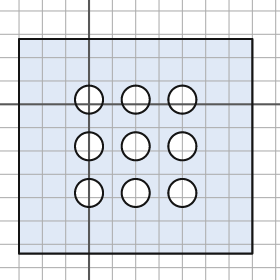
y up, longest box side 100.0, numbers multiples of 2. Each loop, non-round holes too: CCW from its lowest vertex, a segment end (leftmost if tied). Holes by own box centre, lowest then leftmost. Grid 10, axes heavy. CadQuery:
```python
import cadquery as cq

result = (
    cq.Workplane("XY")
    .moveTo(-30.0, -64.0)
    .lineTo(70.0, -64.0)
    .lineTo(70.0, 28.0)
    .lineTo(-30.0, 28.0)
    .close()
    .moveTo(0.0, -38.0)
    .circle(6.0)
    .moveTo(20.0, -38.0)
    .circle(6.0)
    .moveTo(40.0, -38.0)
    .circle(6.0)
    .moveTo(0.0, -18.0)
    .circle(6.0)
    .moveTo(20.0, -18.0)
    .circle(6.0)
    .moveTo(40.0, -18.0)
    .circle(6.0)
    .moveTo(0.0, 2.0)
    .circle(6.0)
    .moveTo(20.0, 2.0)
    .circle(6.0)
    .moveTo(40.0, 2.0)
    .circle(6.0)
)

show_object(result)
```